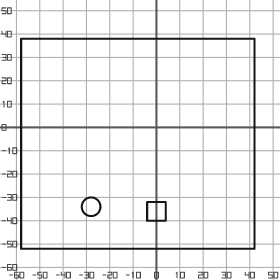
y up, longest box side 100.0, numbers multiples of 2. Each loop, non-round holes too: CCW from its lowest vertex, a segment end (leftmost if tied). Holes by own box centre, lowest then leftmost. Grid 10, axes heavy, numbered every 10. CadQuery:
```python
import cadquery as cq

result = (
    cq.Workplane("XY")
    .moveTo(-58.0, -52.0)
    .lineTo(42.0, -52.0)
    .lineTo(42.0, 38.0)
    .lineTo(-58.0, 38.0)
    .close()
    .moveTo(-4.0, -40.0)
    .lineTo(4.0, -40.0)
    .lineTo(4.0, -32.0)
    .lineTo(-4.0, -32.0)
    .close()
    .moveTo(-28.0, -34.0)
    .circle(4.0)
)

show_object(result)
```